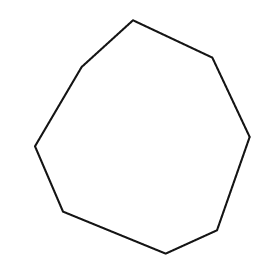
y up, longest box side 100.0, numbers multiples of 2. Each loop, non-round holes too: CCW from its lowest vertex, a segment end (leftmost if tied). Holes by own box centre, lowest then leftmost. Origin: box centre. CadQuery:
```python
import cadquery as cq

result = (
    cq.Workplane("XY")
    .moveTo(10.0, -50.0)
    .lineTo(32.0, -40.0)
    .lineTo(46.0, 0.0)
    .lineTo(30.0, 34.0)
    .lineTo(-4.0, 50.0)
    .lineTo(-26.0, 30.0)
    .lineTo(-46.0, -4.0)
    .lineTo(-34.0, -32.0)
    .close()
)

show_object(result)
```